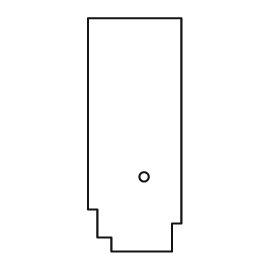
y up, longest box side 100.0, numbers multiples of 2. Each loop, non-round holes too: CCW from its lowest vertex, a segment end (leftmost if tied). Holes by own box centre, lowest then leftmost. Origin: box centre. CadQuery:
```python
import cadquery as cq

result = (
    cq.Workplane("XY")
    .moveTo(-10.0, -50.0)
    .lineTo(16.0, -50.0)
    .lineTo(16.0, -38.0)
    .lineTo(20.0, -38.0)
    .lineTo(20.0, 50.0)
    .lineTo(-20.0, 50.0)
    .lineTo(-20.0, -32.0)
    .lineTo(-16.0, -32.0)
    .lineTo(-16.0, -44.0)
    .lineTo(-10.0, -44.0)
    .close()
    .moveTo(4.0, -18.0)
    .circle(2.0)
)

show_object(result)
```